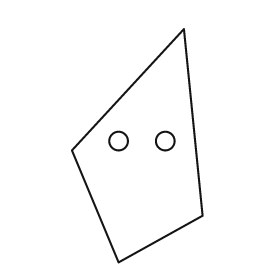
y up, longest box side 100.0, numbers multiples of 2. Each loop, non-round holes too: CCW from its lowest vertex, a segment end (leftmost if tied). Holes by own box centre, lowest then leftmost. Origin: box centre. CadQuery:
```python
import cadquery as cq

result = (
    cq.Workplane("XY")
    .moveTo(-8.0, -50.0)
    .lineTo(28.0, -30.0)
    .lineTo(20.0, 50.0)
    .lineTo(-28.0, -2.0)
    .close()
    .moveTo(-8.0, 2.0)
    .circle(4.0)
    .moveTo(12.0, 2.0)
    .circle(4.0)
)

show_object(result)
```